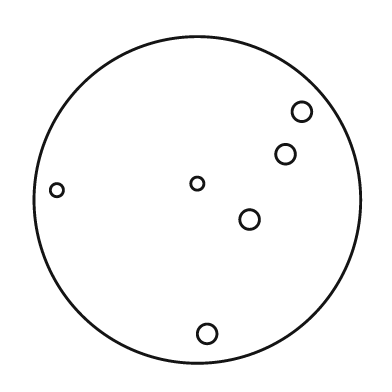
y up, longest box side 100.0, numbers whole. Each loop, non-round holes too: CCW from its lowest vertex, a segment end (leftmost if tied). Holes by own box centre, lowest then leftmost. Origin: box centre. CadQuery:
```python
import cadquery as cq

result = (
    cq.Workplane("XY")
    .moveTo(0.0, 0.0)
    .circle(50.0)
    .moveTo(3.0, -41.0)
    .circle(3.0)
    .moveTo(16.0, -6.0)
    .circle(3.0)
    .moveTo(-43.0, 3.0)
    .circle(2.0)
    .moveTo(0.0, 5.0)
    .circle(2.0)
    .moveTo(27.0, 14.0)
    .circle(3.0)
    .moveTo(32.0, 27.0)
    .circle(3.0)
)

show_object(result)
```